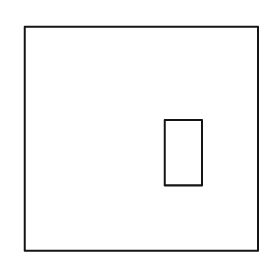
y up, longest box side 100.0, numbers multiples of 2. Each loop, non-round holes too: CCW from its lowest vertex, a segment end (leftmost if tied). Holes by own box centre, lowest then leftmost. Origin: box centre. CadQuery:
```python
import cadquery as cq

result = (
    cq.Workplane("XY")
    .moveTo(-50.0, -48.0)
    .lineTo(50.0, -48.0)
    .lineTo(50.0, 48.0)
    .lineTo(-50.0, 48.0)
    .close()
    .moveTo(10.0, -20.0)
    .lineTo(26.0, -20.0)
    .lineTo(26.0, 8.0)
    .lineTo(10.0, 8.0)
    .close()
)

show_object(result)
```